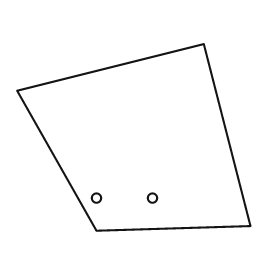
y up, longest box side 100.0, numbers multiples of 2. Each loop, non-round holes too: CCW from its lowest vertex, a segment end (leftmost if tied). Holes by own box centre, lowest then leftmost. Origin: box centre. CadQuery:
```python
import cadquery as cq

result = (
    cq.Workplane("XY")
    .moveTo(-16.0, -40.0)
    .lineTo(50.0, -38.0)
    .lineTo(30.0, 40.0)
    .lineTo(-50.0, 20.0)
    .close()
    .moveTo(-16.0, -26.0)
    .circle(2.0)
    .moveTo(8.0, -26.0)
    .circle(2.0)
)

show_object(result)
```